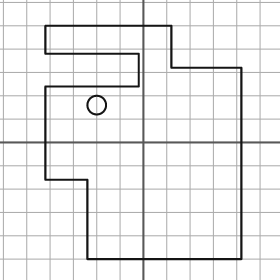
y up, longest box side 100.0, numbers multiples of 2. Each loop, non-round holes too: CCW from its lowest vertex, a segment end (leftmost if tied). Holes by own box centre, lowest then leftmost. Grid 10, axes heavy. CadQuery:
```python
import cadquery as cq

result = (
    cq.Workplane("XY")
    .moveTo(-24.0, -50.0)
    .lineTo(42.0, -50.0)
    .lineTo(42.0, 32.0)
    .lineTo(12.0, 32.0)
    .lineTo(12.0, 50.0)
    .lineTo(-42.0, 50.0)
    .lineTo(-42.0, 38.0)
    .lineTo(-2.0, 38.0)
    .lineTo(-2.0, 24.0)
    .lineTo(-42.0, 24.0)
    .lineTo(-42.0, -16.0)
    .lineTo(-24.0, -16.0)
    .close()
    .moveTo(-20.0, 16.0)
    .circle(4.0)
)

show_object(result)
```